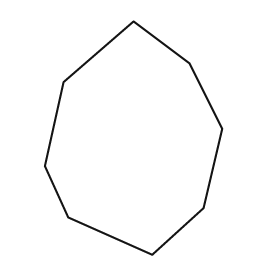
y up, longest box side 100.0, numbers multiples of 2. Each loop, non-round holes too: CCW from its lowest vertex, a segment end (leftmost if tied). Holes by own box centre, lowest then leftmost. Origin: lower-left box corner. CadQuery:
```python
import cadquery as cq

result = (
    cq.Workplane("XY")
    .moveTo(46.0, 0.0)
    .lineTo(68.0, 20.0)
    .lineTo(76.0, 54.0)
    .lineTo(62.0, 82.0)
    .lineTo(38.0, 100.0)
    .lineTo(8.0, 74.0)
    .lineTo(0.0, 38.0)
    .lineTo(10.0, 16.0)
    .close()
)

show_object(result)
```